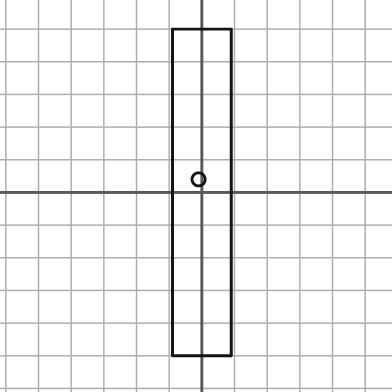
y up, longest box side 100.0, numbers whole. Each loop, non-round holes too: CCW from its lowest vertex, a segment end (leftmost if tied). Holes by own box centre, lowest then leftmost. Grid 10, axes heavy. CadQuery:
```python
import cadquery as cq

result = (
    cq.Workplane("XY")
    .moveTo(-9.0, -50.0)
    .lineTo(9.0, -50.0)
    .lineTo(9.0, 50.0)
    .lineTo(-9.0, 50.0)
    .close()
    .moveTo(-1.0, 4.0)
    .circle(2.0)
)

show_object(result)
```